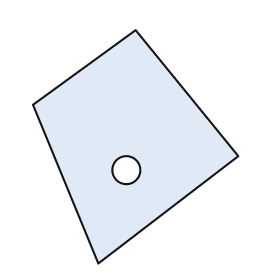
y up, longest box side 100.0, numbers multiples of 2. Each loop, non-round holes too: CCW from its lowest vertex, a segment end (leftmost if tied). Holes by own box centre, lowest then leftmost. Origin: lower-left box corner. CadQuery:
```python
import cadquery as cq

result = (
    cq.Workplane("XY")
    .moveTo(28.0, 0.0)
    .lineTo(88.0, 46.0)
    .lineTo(44.0, 100.0)
    .lineTo(0.0, 68.0)
    .close()
    .moveTo(40.0, 40.0)
    .circle(6.0)
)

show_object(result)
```